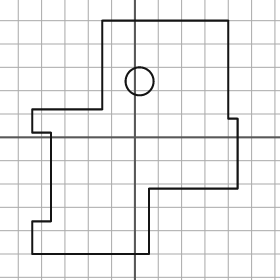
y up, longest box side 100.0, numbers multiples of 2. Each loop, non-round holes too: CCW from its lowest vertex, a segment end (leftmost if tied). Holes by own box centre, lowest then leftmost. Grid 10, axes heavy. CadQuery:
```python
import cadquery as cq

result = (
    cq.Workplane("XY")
    .moveTo(-44.0, -50.0)
    .lineTo(6.0, -50.0)
    .lineTo(6.0, -22.0)
    .lineTo(44.0, -22.0)
    .lineTo(44.0, 8.0)
    .lineTo(40.0, 8.0)
    .lineTo(40.0, 50.0)
    .lineTo(-14.0, 50.0)
    .lineTo(-14.0, 12.0)
    .lineTo(-44.0, 12.0)
    .lineTo(-44.0, 2.0)
    .lineTo(-36.0, 2.0)
    .lineTo(-36.0, -36.0)
    .lineTo(-44.0, -36.0)
    .close()
    .moveTo(2.0, 24.0)
    .circle(6.0)
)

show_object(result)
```